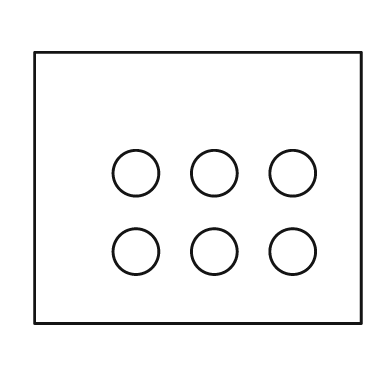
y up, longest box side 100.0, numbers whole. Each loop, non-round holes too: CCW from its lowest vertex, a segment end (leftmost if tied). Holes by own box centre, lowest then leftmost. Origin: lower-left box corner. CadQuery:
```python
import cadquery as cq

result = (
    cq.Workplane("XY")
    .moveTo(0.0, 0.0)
    .lineTo(100.0, 0.0)
    .lineTo(100.0, 83.0)
    .lineTo(0.0, 83.0)
    .close()
    .moveTo(31.0, 22.0)
    .circle(7.0)
    .moveTo(55.0, 22.0)
    .circle(7.0)
    .moveTo(79.0, 22.0)
    .circle(7.0)
    .moveTo(31.0, 46.0)
    .circle(7.0)
    .moveTo(55.0, 46.0)
    .circle(7.0)
    .moveTo(79.0, 46.0)
    .circle(7.0)
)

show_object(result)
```